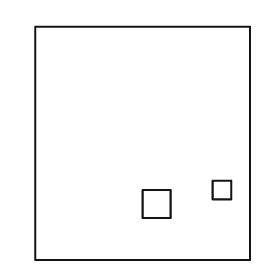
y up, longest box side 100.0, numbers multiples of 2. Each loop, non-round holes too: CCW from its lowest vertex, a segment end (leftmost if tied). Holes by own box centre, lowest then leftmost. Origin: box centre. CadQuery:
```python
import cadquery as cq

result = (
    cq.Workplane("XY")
    .moveTo(-46.0, -50.0)
    .lineTo(46.0, -50.0)
    .lineTo(46.0, 50.0)
    .lineTo(-46.0, 50.0)
    .close()
    .moveTo(0.0, -32.0)
    .lineTo(12.0, -32.0)
    .lineTo(12.0, -20.0)
    .lineTo(0.0, -20.0)
    .close()
    .moveTo(30.0, -24.0)
    .lineTo(38.0, -24.0)
    .lineTo(38.0, -16.0)
    .lineTo(30.0, -16.0)
    .close()
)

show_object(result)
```